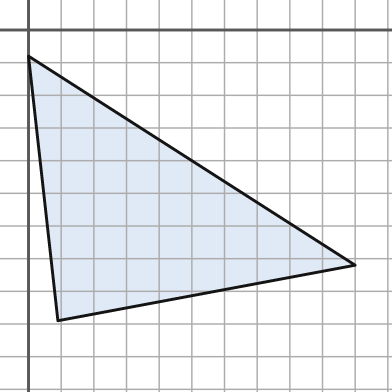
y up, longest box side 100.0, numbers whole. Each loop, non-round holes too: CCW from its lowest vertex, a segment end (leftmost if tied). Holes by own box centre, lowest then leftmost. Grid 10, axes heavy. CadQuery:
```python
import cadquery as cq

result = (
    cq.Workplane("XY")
    .moveTo(9.0, -89.0)
    .lineTo(100.0, -72.0)
    .lineTo(0.0, -8.0)
    .close()
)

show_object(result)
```